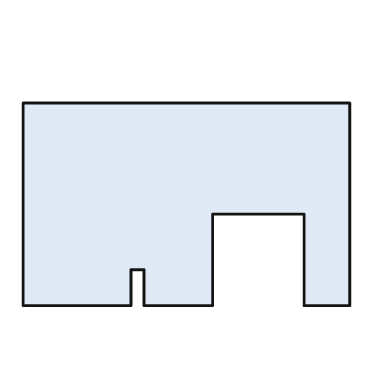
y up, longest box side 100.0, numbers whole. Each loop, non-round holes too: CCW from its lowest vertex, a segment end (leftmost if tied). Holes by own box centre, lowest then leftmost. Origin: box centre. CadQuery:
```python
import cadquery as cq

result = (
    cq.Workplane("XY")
    .moveTo(-50.0, -31.0)
    .lineTo(-17.0, -31.0)
    .lineTo(-17.0, -20.0)
    .lineTo(-13.0, -20.0)
    .lineTo(-13.0, -31.0)
    .lineTo(8.0, -31.0)
    .lineTo(8.0, -3.0)
    .lineTo(36.0, -3.0)
    .lineTo(36.0, -31.0)
    .lineTo(50.0, -31.0)
    .lineTo(50.0, 31.0)
    .lineTo(-50.0, 31.0)
    .close()
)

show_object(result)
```